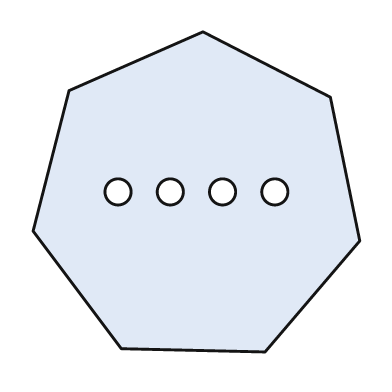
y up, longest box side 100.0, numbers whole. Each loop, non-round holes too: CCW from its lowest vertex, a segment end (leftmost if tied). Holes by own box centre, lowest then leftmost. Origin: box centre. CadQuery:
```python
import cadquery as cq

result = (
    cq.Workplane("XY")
    .moveTo(21.0, -49.0)
    .lineTo(50.0, -15.0)
    .lineTo(41.0, 29.0)
    .lineTo(2.0, 49.0)
    .lineTo(-39.0, 31.0)
    .lineTo(-50.0, -12.0)
    .lineTo(-23.0, -48.0)
    .close()
    .moveTo(-24.0, 0.0)
    .circle(4.0)
    .moveTo(-8.0, 0.0)
    .circle(4.0)
    .moveTo(8.0, 0.0)
    .circle(4.0)
    .moveTo(24.0, 0.0)
    .circle(4.0)
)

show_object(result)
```